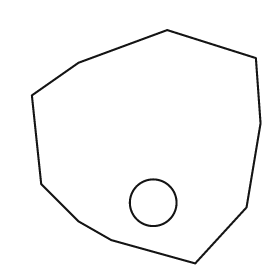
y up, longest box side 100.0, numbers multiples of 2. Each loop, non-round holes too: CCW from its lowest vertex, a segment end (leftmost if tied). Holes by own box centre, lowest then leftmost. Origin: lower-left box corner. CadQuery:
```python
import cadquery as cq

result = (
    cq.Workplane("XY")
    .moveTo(70.0, 0.0)
    .lineTo(92.0, 24.0)
    .lineTo(98.0, 60.0)
    .lineTo(96.0, 88.0)
    .lineTo(58.0, 100.0)
    .lineTo(20.0, 86.0)
    .lineTo(0.0, 72.0)
    .lineTo(4.0, 34.0)
    .lineTo(20.0, 18.0)
    .lineTo(34.0, 10.0)
    .close()
    .moveTo(52.0, 26.0)
    .circle(10.0)
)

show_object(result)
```